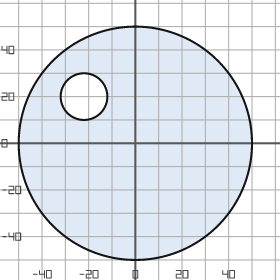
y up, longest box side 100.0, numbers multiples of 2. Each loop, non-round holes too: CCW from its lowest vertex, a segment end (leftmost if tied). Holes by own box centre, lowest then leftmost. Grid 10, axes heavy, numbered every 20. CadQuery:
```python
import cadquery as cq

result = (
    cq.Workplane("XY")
    .moveTo(0.0, 0.0)
    .circle(50.0)
    .moveTo(-22.0, 20.0)
    .circle(10.0)
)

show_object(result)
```